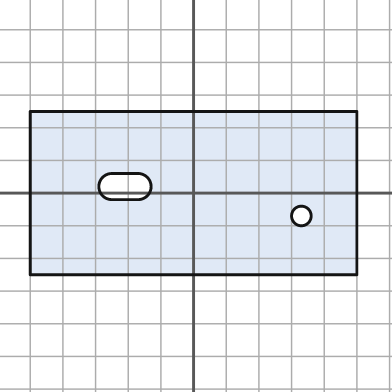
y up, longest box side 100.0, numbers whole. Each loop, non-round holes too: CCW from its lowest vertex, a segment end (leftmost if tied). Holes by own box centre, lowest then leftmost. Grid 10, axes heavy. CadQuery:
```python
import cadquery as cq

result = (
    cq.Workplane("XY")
    .moveTo(-50.0, -25.0)
    .lineTo(50.0, -25.0)
    .lineTo(50.0, 25.0)
    .lineTo(-50.0, 25.0)
    .close()
    .moveTo(33.0, -7.0)
    .circle(3.0)
    .moveTo(-25.0, -2.0)
    .lineTo(-17.0, -2.0)
    .threePointArc((-13.0, 2.0), (-17.0, 6.0))
    .lineTo(-25.0, 6.0)
    .threePointArc((-29.0, 2.0), (-25.0, -2.0))
    .close()
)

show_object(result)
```